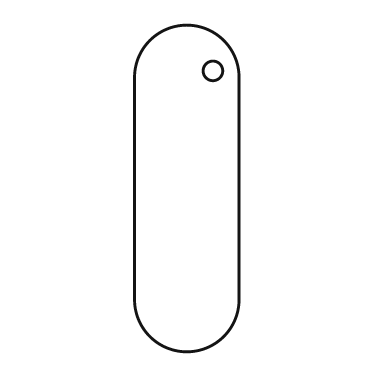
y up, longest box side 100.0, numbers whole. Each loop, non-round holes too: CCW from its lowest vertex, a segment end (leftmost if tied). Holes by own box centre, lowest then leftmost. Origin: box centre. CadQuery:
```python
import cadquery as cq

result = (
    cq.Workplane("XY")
    .moveTo(-16.0, -34.0)
    .threePointArc((0.0, -50.0), (16.0, -34.0))
    .lineTo(16.0, 34.0)
    .threePointArc((0.0, 50.0), (-16.0, 34.0))
    .close()
    .moveTo(8.0, 36.0)
    .circle(3.0)
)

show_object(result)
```